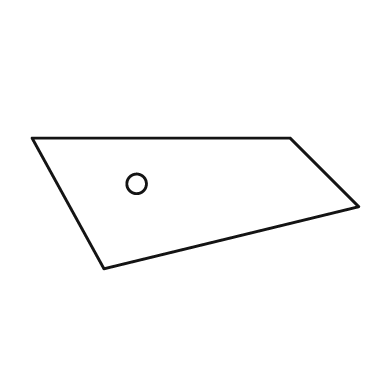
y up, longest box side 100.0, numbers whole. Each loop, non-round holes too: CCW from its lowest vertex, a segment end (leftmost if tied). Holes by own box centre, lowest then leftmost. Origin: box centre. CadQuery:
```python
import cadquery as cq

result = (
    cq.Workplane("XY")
    .moveTo(-28.0, -20.0)
    .lineTo(50.0, -1.0)
    .lineTo(29.0, 20.0)
    .lineTo(-50.0, 20.0)
    .close()
    .moveTo(-18.0, 6.0)
    .circle(3.0)
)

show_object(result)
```